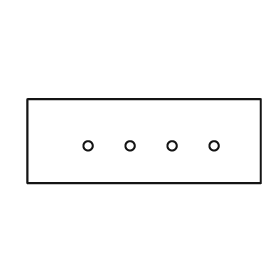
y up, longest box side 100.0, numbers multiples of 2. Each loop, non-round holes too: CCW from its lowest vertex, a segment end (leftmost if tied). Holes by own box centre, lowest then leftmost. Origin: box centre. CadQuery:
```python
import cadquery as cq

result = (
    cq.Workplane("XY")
    .moveTo(-50.0, -18.0)
    .lineTo(50.0, -18.0)
    .lineTo(50.0, 18.0)
    .lineTo(-50.0, 18.0)
    .close()
    .moveTo(-24.0, -2.0)
    .circle(2.0)
    .moveTo(-6.0, -2.0)
    .circle(2.0)
    .moveTo(12.0, -2.0)
    .circle(2.0)
    .moveTo(30.0, -2.0)
    .circle(2.0)
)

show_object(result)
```